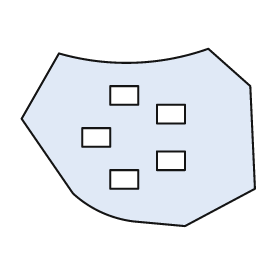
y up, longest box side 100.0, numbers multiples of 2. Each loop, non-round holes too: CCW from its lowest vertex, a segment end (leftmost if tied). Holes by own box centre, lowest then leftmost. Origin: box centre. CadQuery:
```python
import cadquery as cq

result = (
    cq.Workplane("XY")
    .moveTo(20.0, -38.0)
    .lineTo(50.0, -22.0)
    .lineTo(48.0, 22.0)
    .lineTo(30.0, 38.0)
    .threePointArc((-2.0, 32.0), (-34.0, 36.0))
    .lineTo(-50.0, 8.0)
    .lineTo(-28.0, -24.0)
    .threePointArc((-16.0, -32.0), (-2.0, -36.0))
    .close()
    .moveTo(-12.0, -22.0)
    .lineTo(0.0, -22.0)
    .lineTo(0.0, -14.0)
    .lineTo(-12.0, -14.0)
    .close()
    .moveTo(8.0, -14.0)
    .lineTo(20.0, -14.0)
    .lineTo(20.0, -6.0)
    .lineTo(8.0, -6.0)
    .close()
    .moveTo(-24.0, -4.0)
    .lineTo(-12.0, -4.0)
    .lineTo(-12.0, 4.0)
    .lineTo(-24.0, 4.0)
    .close()
    .moveTo(8.0, 6.0)
    .lineTo(20.0, 6.0)
    .lineTo(20.0, 14.0)
    .lineTo(8.0, 14.0)
    .close()
    .moveTo(-12.0, 14.0)
    .lineTo(0.0, 14.0)
    .lineTo(0.0, 22.0)
    .lineTo(-12.0, 22.0)
    .close()
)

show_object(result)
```